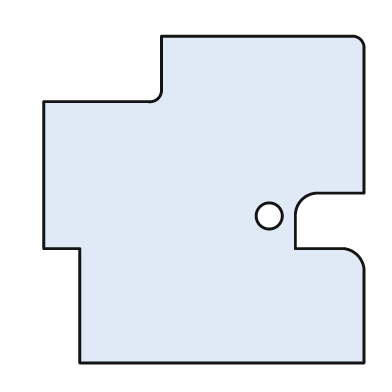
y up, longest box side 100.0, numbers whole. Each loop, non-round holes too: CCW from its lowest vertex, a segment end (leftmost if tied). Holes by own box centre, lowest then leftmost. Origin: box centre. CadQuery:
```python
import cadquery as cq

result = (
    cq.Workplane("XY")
    .moveTo(-38.0, -50.0)
    .lineTo(49.0, -50.0)
    .lineTo(49.0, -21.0)
    .threePointArc((47.0, -17.0), (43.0, -15.0))
    .lineTo(28.0, -15.0)
    .lineTo(28.0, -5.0)
    .threePointArc((30.0, 0.0), (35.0, 2.0))
    .lineTo(49.0, 2.0)
    .lineTo(49.0, 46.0)
    .threePointArc((48.0, 49.0), (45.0, 50.0))
    .lineTo(-13.0, 50.0)
    .lineTo(-13.0, 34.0)
    .threePointArc((-14.0, 31.0), (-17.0, 30.0))
    .lineTo(-49.0, 30.0)
    .lineTo(-49.0, -15.0)
    .lineTo(-38.0, -15.0)
    .close()
    .moveTo(20.0, -5.0)
    .circle(4.0)
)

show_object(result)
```